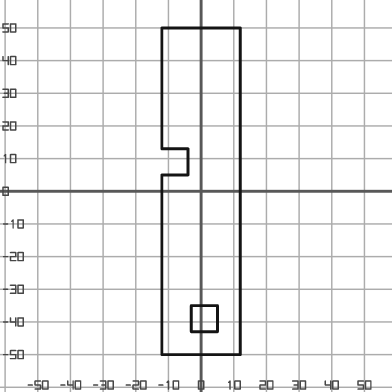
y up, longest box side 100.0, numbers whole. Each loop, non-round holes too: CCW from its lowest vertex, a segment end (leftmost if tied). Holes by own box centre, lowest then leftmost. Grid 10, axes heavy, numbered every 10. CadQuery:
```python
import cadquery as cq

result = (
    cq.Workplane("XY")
    .moveTo(-12.0, -50.0)
    .lineTo(12.0, -50.0)
    .lineTo(12.0, 50.0)
    .lineTo(-12.0, 50.0)
    .lineTo(-12.0, 13.0)
    .lineTo(-4.0, 13.0)
    .lineTo(-4.0, 5.0)
    .lineTo(-12.0, 5.0)
    .close()
    .moveTo(-3.0, -43.0)
    .lineTo(5.0, -43.0)
    .lineTo(5.0, -35.0)
    .lineTo(-3.0, -35.0)
    .close()
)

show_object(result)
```